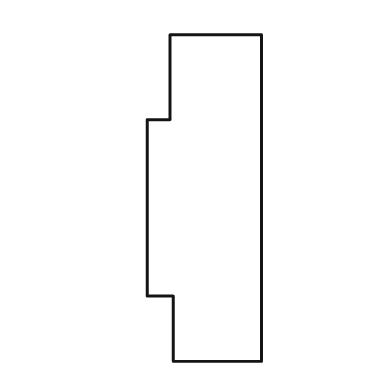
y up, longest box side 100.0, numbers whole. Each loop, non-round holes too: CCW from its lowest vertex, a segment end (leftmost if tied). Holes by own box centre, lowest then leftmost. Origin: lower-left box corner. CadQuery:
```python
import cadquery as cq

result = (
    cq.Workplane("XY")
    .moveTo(8.0, 0.0)
    .lineTo(35.0, 0.0)
    .lineTo(35.0, 100.0)
    .lineTo(7.0, 100.0)
    .lineTo(7.0, 74.0)
    .lineTo(0.0, 74.0)
    .lineTo(0.0, 20.0)
    .lineTo(8.0, 20.0)
    .close()
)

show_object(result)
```